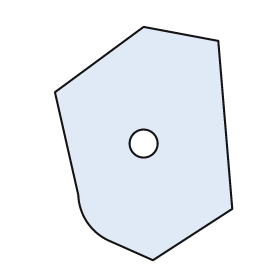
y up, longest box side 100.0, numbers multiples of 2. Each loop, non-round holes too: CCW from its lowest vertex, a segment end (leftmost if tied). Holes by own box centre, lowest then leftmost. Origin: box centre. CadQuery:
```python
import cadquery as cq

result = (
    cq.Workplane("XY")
    .moveTo(4.0, -50.0)
    .lineTo(38.0, -28.0)
    .lineTo(32.0, 44.0)
    .lineTo(0.0, 50.0)
    .lineTo(-38.0, 22.0)
    .lineTo(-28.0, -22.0)
    .threePointArc((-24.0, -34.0), (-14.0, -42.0))
    .close()
    .moveTo(0.0, 0.0)
    .circle(6.0)
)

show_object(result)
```